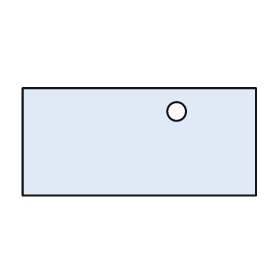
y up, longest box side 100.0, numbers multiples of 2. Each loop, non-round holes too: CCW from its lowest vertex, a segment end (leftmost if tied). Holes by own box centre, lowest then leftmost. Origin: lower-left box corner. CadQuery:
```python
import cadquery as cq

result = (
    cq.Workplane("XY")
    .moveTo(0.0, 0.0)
    .lineTo(100.0, 0.0)
    .lineTo(100.0, 46.0)
    .lineTo(0.0, 46.0)
    .close()
    .moveTo(66.0, 36.0)
    .circle(4.0)
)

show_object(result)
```